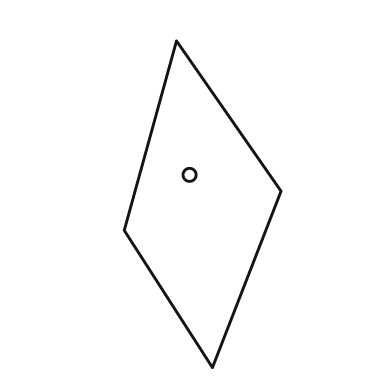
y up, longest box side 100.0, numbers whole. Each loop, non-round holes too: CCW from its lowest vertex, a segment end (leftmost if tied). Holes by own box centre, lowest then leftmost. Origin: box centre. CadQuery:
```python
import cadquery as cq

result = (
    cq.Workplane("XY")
    .moveTo(3.0, -50.0)
    .lineTo(24.0, 4.0)
    .lineTo(-8.0, 50.0)
    .lineTo(-24.0, -8.0)
    .close()
    .moveTo(-4.0, 9.0)
    .circle(2.0)
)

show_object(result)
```